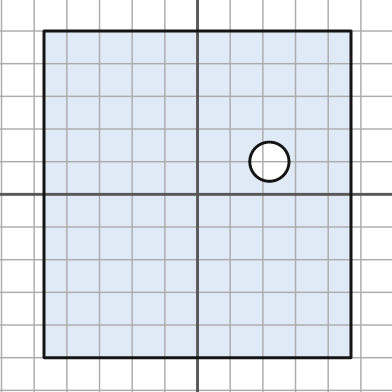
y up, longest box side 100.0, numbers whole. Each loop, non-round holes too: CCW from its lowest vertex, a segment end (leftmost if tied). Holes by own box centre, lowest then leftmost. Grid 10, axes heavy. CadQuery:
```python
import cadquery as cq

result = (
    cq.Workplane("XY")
    .moveTo(-47.0, -50.0)
    .lineTo(47.0, -50.0)
    .lineTo(47.0, 50.0)
    .lineTo(-47.0, 50.0)
    .close()
    .moveTo(22.0, 10.0)
    .circle(6.0)
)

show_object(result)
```